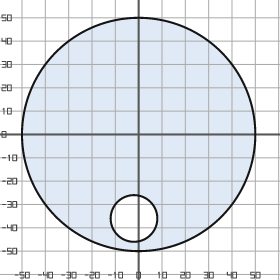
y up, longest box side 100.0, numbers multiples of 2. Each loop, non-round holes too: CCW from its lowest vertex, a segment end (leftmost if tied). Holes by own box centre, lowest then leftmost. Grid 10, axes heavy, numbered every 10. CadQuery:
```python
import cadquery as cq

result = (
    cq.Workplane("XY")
    .moveTo(0.0, 0.0)
    .circle(50.0)
    .moveTo(-2.0, -36.0)
    .circle(10.0)
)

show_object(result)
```